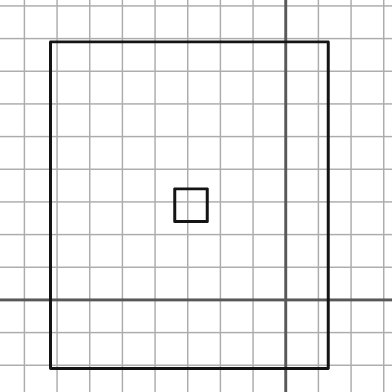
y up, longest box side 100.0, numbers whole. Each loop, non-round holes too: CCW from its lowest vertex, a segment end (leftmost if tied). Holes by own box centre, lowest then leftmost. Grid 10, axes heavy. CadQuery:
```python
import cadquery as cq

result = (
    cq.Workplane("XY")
    .moveTo(-72.0, -21.0)
    .lineTo(13.0, -21.0)
    .lineTo(13.0, 79.0)
    .lineTo(-72.0, 79.0)
    .close()
    .moveTo(-34.0, 24.0)
    .lineTo(-24.0, 24.0)
    .lineTo(-24.0, 34.0)
    .lineTo(-34.0, 34.0)
    .close()
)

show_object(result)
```